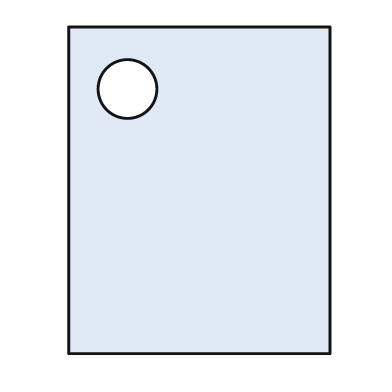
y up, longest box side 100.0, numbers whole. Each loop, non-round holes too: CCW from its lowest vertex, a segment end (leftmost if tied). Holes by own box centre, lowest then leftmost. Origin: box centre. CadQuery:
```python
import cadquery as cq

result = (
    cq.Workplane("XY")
    .moveTo(-40.0, -50.0)
    .lineTo(40.0, -50.0)
    .lineTo(40.0, 50.0)
    .lineTo(-40.0, 50.0)
    .close()
    .moveTo(-22.0, 31.0)
    .circle(9.0)
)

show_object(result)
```